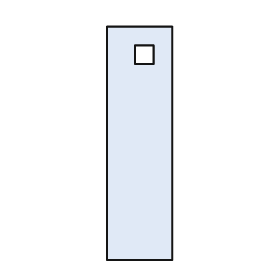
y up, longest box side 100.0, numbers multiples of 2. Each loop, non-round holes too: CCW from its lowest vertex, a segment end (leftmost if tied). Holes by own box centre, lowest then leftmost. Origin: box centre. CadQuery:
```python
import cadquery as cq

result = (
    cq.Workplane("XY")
    .moveTo(-14.0, -50.0)
    .lineTo(14.0, -50.0)
    .lineTo(14.0, 50.0)
    .lineTo(-14.0, 50.0)
    .close()
    .moveTo(-2.0, 34.0)
    .lineTo(6.0, 34.0)
    .lineTo(6.0, 42.0)
    .lineTo(-2.0, 42.0)
    .close()
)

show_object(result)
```